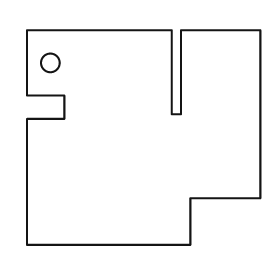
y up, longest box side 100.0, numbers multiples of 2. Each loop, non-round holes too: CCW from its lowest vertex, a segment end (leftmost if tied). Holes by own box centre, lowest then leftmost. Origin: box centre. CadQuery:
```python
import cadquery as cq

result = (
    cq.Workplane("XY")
    .moveTo(-50.0, -46.0)
    .lineTo(20.0, -46.0)
    .lineTo(20.0, -26.0)
    .lineTo(50.0, -26.0)
    .lineTo(50.0, 46.0)
    .lineTo(16.0, 46.0)
    .lineTo(16.0, 10.0)
    .lineTo(12.0, 10.0)
    .lineTo(12.0, 46.0)
    .lineTo(-50.0, 46.0)
    .lineTo(-50.0, 18.0)
    .lineTo(-34.0, 18.0)
    .lineTo(-34.0, 8.0)
    .lineTo(-50.0, 8.0)
    .close()
    .moveTo(-40.0, 32.0)
    .circle(4.0)
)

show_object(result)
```